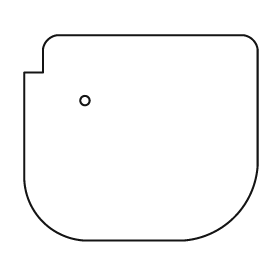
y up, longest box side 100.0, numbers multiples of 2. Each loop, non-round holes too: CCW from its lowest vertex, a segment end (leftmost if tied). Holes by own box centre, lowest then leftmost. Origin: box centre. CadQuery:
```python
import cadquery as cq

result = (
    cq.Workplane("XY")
    .moveTo(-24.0, -44.0)
    .lineTo(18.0, -44.0)
    .threePointArc((40.0, -34.0), (50.0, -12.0))
    .lineTo(50.0, 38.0)
    .threePointArc((48.0, 42.0), (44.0, 44.0))
    .lineTo(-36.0, 44.0)
    .threePointArc((-40.0, 42.0), (-42.0, 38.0))
    .lineTo(-42.0, 28.0)
    .lineTo(-50.0, 28.0)
    .lineTo(-50.0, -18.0)
    .threePointArc((-42.0, -36.0), (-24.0, -44.0))
    .close()
    .moveTo(-24.0, 16.0)
    .circle(2.0)
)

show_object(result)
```